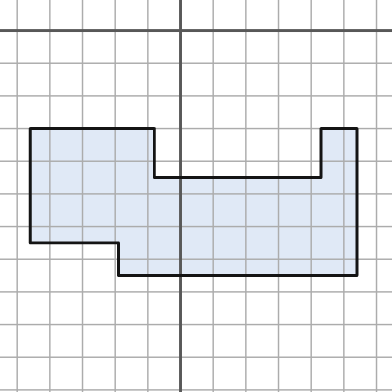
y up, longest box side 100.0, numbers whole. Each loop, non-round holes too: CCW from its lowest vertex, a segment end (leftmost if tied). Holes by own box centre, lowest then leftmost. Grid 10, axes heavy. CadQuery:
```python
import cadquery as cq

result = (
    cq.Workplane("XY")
    .moveTo(-19.0, -75.0)
    .lineTo(54.0, -75.0)
    .lineTo(54.0, -30.0)
    .lineTo(43.0, -30.0)
    .lineTo(43.0, -45.0)
    .lineTo(-8.0, -45.0)
    .lineTo(-8.0, -30.0)
    .lineTo(-46.0, -30.0)
    .lineTo(-46.0, -65.0)
    .lineTo(-19.0, -65.0)
    .close()
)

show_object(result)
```